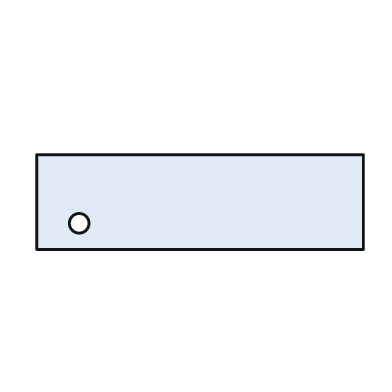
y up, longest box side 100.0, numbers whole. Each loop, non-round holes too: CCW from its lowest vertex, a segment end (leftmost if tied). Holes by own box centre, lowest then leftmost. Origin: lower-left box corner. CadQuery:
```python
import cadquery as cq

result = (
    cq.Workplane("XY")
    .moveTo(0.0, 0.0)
    .lineTo(100.0, 0.0)
    .lineTo(100.0, 29.0)
    .lineTo(0.0, 29.0)
    .close()
    .moveTo(13.0, 8.0)
    .circle(3.0)
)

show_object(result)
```